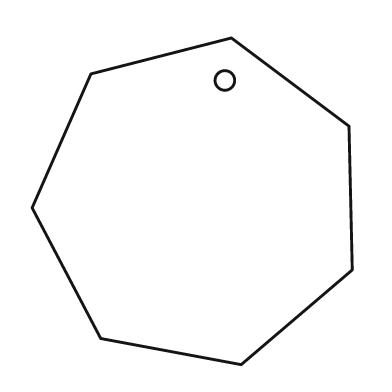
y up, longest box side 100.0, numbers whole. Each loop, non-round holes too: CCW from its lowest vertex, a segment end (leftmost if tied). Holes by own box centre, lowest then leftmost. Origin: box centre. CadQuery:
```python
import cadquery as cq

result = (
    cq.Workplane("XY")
    .moveTo(15.0, -50.0)
    .lineTo(49.0, -21.0)
    .lineTo(48.0, 23.0)
    .lineTo(12.0, 50.0)
    .lineTo(-31.0, 39.0)
    .lineTo(-49.0, -2.0)
    .lineTo(-28.0, -42.0)
    .close()
    .moveTo(10.0, 37.0)
    .circle(3.0)
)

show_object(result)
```